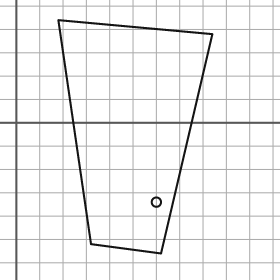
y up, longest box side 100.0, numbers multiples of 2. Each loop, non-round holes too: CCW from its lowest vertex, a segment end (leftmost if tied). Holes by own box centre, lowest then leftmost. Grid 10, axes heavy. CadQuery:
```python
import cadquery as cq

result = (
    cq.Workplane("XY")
    .moveTo(62.0, -56.0)
    .lineTo(84.0, 38.0)
    .lineTo(18.0, 44.0)
    .lineTo(32.0, -52.0)
    .close()
    .moveTo(60.0, -34.0)
    .circle(2.0)
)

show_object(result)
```